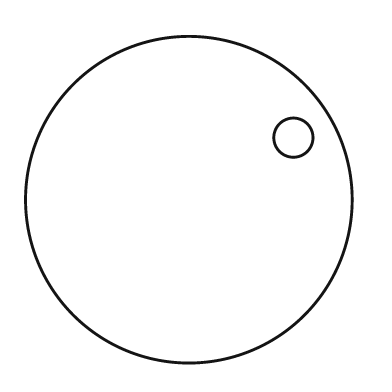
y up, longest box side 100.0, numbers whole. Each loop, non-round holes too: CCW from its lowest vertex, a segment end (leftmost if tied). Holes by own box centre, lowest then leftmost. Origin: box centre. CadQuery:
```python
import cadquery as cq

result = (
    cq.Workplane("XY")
    .moveTo(0.0, 0.0)
    .circle(50.0)
    .moveTo(32.0, 19.0)
    .circle(6.0)
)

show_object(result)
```